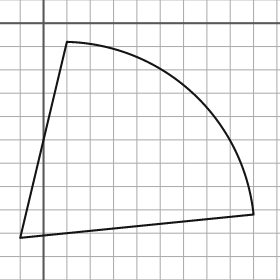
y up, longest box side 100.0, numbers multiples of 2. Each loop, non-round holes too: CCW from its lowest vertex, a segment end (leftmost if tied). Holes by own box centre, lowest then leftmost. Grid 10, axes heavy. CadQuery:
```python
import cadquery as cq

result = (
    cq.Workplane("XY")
    .moveTo(-10.0, -92.0)
    .lineTo(90.0, -82.0)
    .threePointArc((64.0, -30.0), (10.0, -8.0))
    .close()
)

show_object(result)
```